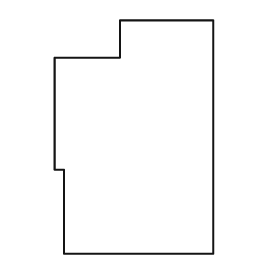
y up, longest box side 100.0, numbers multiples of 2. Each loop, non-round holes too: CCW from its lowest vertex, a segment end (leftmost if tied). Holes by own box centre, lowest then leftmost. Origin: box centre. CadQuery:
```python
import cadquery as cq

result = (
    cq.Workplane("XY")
    .moveTo(-30.0, -50.0)
    .lineTo(34.0, -50.0)
    .lineTo(34.0, 50.0)
    .lineTo(-6.0, 50.0)
    .lineTo(-6.0, 34.0)
    .lineTo(-34.0, 34.0)
    .lineTo(-34.0, -14.0)
    .lineTo(-30.0, -14.0)
    .close()
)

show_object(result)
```